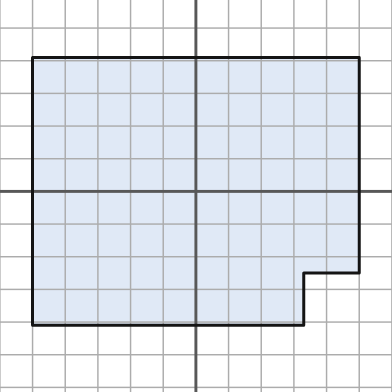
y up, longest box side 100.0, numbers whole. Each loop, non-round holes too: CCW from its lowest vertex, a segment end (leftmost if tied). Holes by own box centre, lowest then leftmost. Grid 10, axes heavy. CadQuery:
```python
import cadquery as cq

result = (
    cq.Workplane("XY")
    .moveTo(-50.0, -41.0)
    .lineTo(33.0, -41.0)
    .lineTo(33.0, -25.0)
    .lineTo(50.0, -25.0)
    .lineTo(50.0, 41.0)
    .lineTo(-50.0, 41.0)
    .close()
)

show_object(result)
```